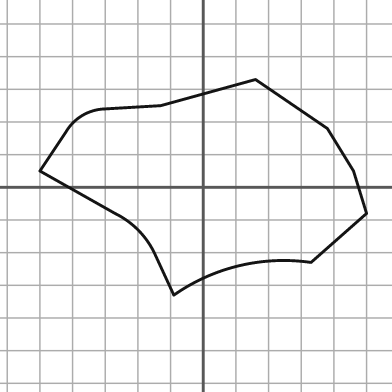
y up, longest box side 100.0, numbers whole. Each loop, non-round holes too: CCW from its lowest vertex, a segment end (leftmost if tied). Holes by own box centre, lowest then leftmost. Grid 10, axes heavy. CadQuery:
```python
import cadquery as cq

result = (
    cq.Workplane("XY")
    .moveTo(-9.0, -33.0)
    .threePointArc((11.0, -24.0), (33.0, -23.0))
    .lineTo(50.0, -8.0)
    .lineTo(46.0, 5.0)
    .lineTo(38.0, 18.0)
    .lineTo(16.0, 33.0)
    .lineTo(-13.0, 25.0)
    .lineTo(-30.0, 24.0)
    .threePointArc((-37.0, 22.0), (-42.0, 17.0))
    .lineTo(-50.0, 5.0)
    .lineTo(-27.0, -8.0)
    .threePointArc((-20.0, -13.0), (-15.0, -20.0))
    .close()
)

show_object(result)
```